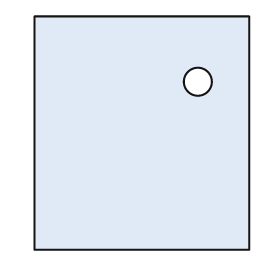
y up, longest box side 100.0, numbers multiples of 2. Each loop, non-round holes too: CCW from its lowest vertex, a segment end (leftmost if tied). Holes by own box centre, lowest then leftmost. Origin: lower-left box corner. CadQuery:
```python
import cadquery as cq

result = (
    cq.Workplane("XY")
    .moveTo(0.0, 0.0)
    .lineTo(92.0, 0.0)
    .lineTo(92.0, 100.0)
    .lineTo(0.0, 100.0)
    .close()
    .moveTo(70.0, 72.0)
    .circle(6.0)
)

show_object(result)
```